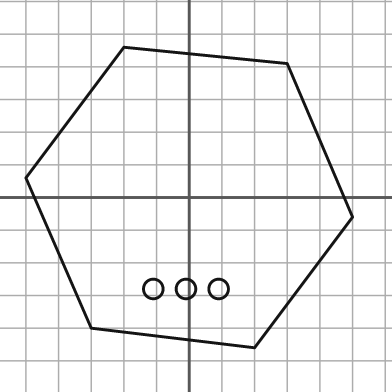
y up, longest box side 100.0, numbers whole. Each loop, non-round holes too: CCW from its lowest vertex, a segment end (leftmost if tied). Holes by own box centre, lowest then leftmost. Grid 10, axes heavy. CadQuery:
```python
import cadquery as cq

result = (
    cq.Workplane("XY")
    .moveTo(20.0, -46.0)
    .lineTo(50.0, -6.0)
    .lineTo(30.0, 41.0)
    .lineTo(-20.0, 46.0)
    .lineTo(-50.0, 6.0)
    .lineTo(-30.0, -40.0)
    .close()
    .moveTo(-11.0, -28.0)
    .circle(3.0)
    .moveTo(-1.0, -28.0)
    .circle(3.0)
    .moveTo(9.0, -28.0)
    .circle(3.0)
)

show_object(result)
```